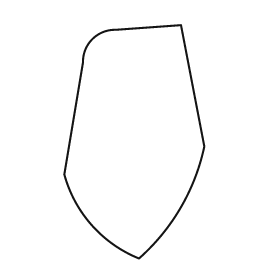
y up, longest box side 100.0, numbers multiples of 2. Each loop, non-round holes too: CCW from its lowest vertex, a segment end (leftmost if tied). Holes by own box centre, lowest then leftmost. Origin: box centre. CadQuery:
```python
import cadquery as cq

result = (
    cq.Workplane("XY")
    .moveTo(2.0, -50.0)
    .threePointArc((20.0, -28.0), (30.0, -2.0))
    .lineTo(20.0, 50.0)
    .lineTo(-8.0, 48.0)
    .threePointArc((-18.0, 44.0), (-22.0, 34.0))
    .lineTo(-30.0, -14.0)
    .threePointArc((-18.0, -36.0), (2.0, -50.0))
    .close()
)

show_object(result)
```